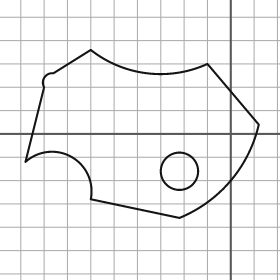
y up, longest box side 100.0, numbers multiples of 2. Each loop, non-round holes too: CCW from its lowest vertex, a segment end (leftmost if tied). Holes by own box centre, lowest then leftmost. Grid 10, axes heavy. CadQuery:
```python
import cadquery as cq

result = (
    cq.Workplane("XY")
    .moveTo(-22.0, -36.0)
    .threePointArc((0.0, -20.0), (12.0, 4.0))
    .lineTo(-10.0, 30.0)
    .threePointArc((-36.0, 26.0), (-60.0, 36.0))
    .lineTo(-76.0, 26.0)
    .threePointArc((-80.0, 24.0), (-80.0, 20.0))
    .lineTo(-88.0, -12.0)
    .threePointArc((-68.0, -10.0), (-60.0, -28.0))
    .close()
    .moveTo(-22.0, -16.0)
    .circle(8.0)
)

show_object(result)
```